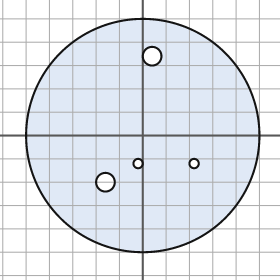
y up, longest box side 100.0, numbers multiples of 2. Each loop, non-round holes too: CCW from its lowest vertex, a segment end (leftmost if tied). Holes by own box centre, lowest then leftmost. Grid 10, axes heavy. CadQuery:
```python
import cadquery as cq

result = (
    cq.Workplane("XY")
    .moveTo(0.0, 0.0)
    .circle(50.0)
    .moveTo(-16.0, -20.0)
    .circle(4.0)
    .moveTo(-2.0, -12.0)
    .circle(2.0)
    .moveTo(22.0, -12.0)
    .circle(2.0)
    .moveTo(4.0, 34.0)
    .circle(4.0)
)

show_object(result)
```